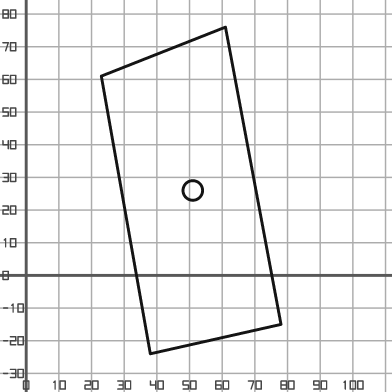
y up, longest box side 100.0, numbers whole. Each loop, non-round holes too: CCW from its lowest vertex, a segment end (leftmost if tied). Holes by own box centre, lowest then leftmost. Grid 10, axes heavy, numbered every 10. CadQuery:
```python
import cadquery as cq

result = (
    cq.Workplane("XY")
    .moveTo(38.0, -24.0)
    .lineTo(78.0, -15.0)
    .lineTo(61.0, 76.0)
    .lineTo(23.0, 61.0)
    .close()
    .moveTo(51.0, 26.0)
    .circle(3.0)
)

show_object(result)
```